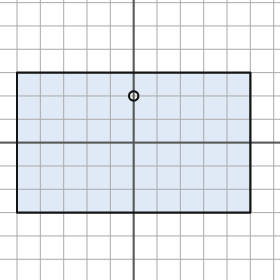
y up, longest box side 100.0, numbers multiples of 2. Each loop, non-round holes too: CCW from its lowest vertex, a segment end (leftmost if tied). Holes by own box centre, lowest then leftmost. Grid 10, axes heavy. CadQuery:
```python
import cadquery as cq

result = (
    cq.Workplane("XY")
    .moveTo(-50.0, -30.0)
    .lineTo(50.0, -30.0)
    .lineTo(50.0, 30.0)
    .lineTo(-50.0, 30.0)
    .close()
    .moveTo(0.0, 20.0)
    .circle(2.0)
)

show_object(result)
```